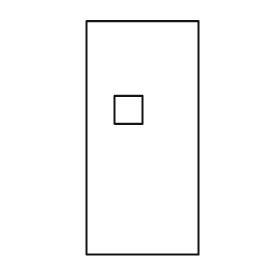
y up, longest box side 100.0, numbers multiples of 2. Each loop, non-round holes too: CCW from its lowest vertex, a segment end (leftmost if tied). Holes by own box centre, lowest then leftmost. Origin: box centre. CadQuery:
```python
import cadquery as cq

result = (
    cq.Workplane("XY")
    .moveTo(-24.0, -50.0)
    .lineTo(24.0, -50.0)
    .lineTo(24.0, 50.0)
    .lineTo(-24.0, 50.0)
    .close()
    .moveTo(-12.0, 6.0)
    .lineTo(0.0, 6.0)
    .lineTo(0.0, 18.0)
    .lineTo(-12.0, 18.0)
    .close()
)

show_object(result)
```